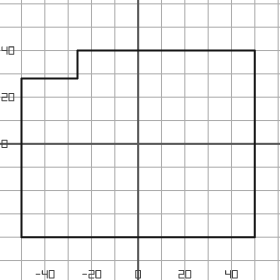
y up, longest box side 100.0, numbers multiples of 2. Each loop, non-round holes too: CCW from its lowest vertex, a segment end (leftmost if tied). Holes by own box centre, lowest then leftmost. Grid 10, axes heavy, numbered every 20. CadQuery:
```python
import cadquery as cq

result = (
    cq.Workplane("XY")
    .moveTo(-50.0, -40.0)
    .lineTo(50.0, -40.0)
    .lineTo(50.0, 40.0)
    .lineTo(-26.0, 40.0)
    .lineTo(-26.0, 28.0)
    .lineTo(-50.0, 28.0)
    .close()
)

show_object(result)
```